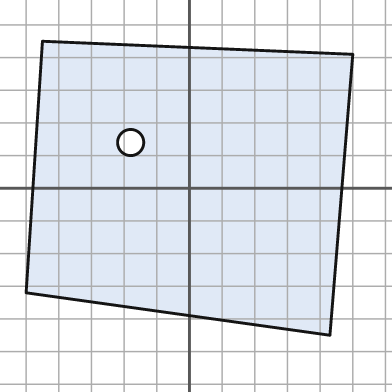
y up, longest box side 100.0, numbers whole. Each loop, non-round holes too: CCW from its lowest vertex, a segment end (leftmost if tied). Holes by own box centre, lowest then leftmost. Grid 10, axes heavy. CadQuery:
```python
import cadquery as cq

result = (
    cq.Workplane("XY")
    .moveTo(43.0, -45.0)
    .lineTo(50.0, 41.0)
    .lineTo(-45.0, 45.0)
    .lineTo(-50.0, -32.0)
    .close()
    .moveTo(-18.0, 14.0)
    .circle(4.0)
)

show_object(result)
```